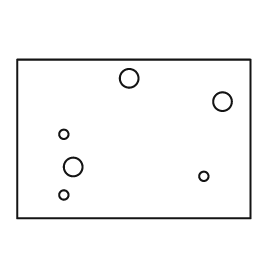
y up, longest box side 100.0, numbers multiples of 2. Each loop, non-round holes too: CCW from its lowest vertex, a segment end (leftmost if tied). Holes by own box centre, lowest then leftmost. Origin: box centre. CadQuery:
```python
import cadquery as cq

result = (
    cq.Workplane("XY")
    .moveTo(-50.0, -34.0)
    .lineTo(50.0, -34.0)
    .lineTo(50.0, 34.0)
    .lineTo(-50.0, 34.0)
    .close()
    .moveTo(-30.0, -24.0)
    .circle(2.0)
    .moveTo(30.0, -16.0)
    .circle(2.0)
    .moveTo(-26.0, -12.0)
    .circle(4.0)
    .moveTo(-30.0, 2.0)
    .circle(2.0)
    .moveTo(38.0, 16.0)
    .circle(4.0)
    .moveTo(-2.0, 26.0)
    .circle(4.0)
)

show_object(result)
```